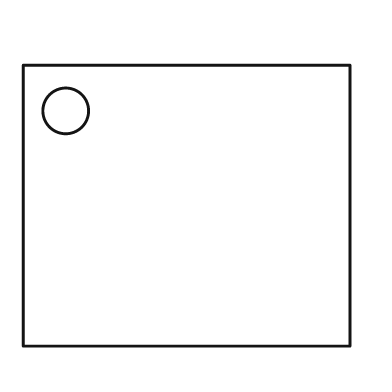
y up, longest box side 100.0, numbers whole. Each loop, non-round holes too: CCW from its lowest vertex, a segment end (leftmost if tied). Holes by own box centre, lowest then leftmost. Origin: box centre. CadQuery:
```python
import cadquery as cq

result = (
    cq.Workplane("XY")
    .moveTo(-50.0, -43.0)
    .lineTo(50.0, -43.0)
    .lineTo(50.0, 43.0)
    .lineTo(-50.0, 43.0)
    .close()
    .moveTo(-37.0, 29.0)
    .circle(7.0)
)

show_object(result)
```